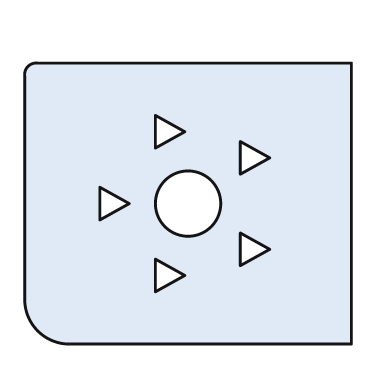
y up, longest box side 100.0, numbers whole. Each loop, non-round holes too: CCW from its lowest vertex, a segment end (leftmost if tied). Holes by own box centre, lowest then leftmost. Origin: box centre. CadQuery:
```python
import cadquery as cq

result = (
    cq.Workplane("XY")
    .moveTo(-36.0, -43.0)
    .lineTo(50.0, -43.0)
    .lineTo(50.0, 43.0)
    .lineTo(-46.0, 43.0)
    .threePointArc((-49.0, 42.0), (-50.0, 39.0))
    .lineTo(-50.0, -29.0)
    .threePointArc((-46.0, -39.0), (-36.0, -43.0))
    .close()
    .moveTo(-10.0, -27.0)
    .lineTo(-1.0, -22.0)
    .lineTo(-10.0, -17.0)
    .close()
    .moveTo(16.0, -19.0)
    .lineTo(25.0, -14.0)
    .lineTo(16.0, -9.0)
    .close()
    .moveTo(-27.0, -5.0)
    .lineTo(-18.0, 0.0)
    .lineTo(-27.0, 5.0)
    .close()
    .moveTo(0.0, 0.0)
    .circle(10.0)
    .moveTo(16.0, 9.0)
    .lineTo(25.0, 14.0)
    .lineTo(16.0, 19.0)
    .close()
    .moveTo(-10.0, 17.0)
    .lineTo(-1.0, 22.0)
    .lineTo(-10.0, 27.0)
    .close()
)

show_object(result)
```